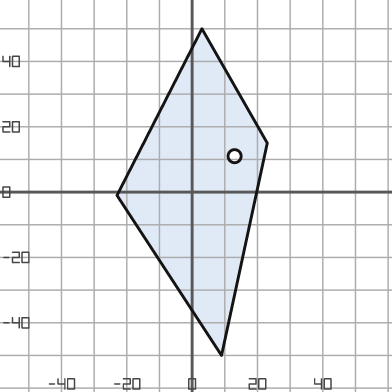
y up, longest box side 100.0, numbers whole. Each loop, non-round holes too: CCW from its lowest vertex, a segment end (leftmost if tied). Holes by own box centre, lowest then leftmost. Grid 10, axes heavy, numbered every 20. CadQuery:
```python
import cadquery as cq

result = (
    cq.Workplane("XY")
    .moveTo(9.0, -50.0)
    .lineTo(23.0, 15.0)
    .lineTo(3.0, 50.0)
    .lineTo(-23.0, -1.0)
    .close()
    .moveTo(13.0, 11.0)
    .circle(2.0)
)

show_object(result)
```